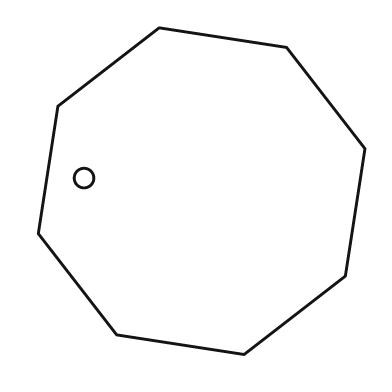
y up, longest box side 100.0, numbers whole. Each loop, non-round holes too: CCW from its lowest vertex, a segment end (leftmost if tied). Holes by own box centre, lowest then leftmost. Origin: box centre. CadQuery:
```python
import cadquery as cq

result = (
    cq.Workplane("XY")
    .moveTo(13.0, -50.0)
    .lineTo(44.0, -26.0)
    .lineTo(50.0, 13.0)
    .lineTo(26.0, 44.0)
    .lineTo(-13.0, 50.0)
    .lineTo(-44.0, 26.0)
    .lineTo(-50.0, -13.0)
    .lineTo(-26.0, -44.0)
    .close()
    .moveTo(-36.0, 4.0)
    .circle(3.0)
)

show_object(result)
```